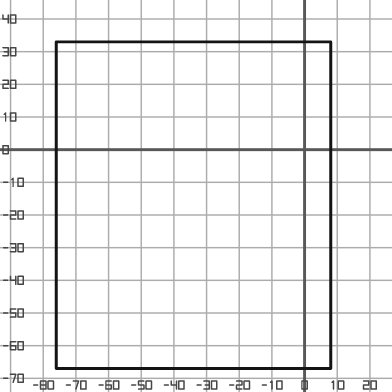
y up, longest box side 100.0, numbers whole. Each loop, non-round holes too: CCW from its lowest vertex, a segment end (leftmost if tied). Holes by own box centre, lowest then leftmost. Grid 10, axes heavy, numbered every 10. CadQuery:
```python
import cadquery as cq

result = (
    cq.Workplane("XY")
    .moveTo(-76.0, -67.0)
    .lineTo(8.0, -67.0)
    .lineTo(8.0, 33.0)
    .lineTo(-76.0, 33.0)
    .close()
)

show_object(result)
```